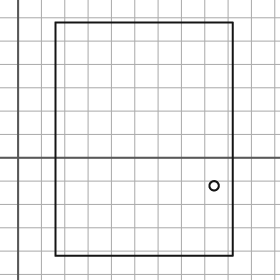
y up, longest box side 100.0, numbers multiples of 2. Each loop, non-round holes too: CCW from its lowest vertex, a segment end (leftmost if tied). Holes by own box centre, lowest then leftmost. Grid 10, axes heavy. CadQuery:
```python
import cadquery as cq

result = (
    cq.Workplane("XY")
    .moveTo(16.0, -42.0)
    .lineTo(92.0, -42.0)
    .lineTo(92.0, 58.0)
    .lineTo(16.0, 58.0)
    .close()
    .moveTo(84.0, -12.0)
    .circle(2.0)
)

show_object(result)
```